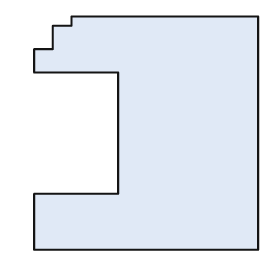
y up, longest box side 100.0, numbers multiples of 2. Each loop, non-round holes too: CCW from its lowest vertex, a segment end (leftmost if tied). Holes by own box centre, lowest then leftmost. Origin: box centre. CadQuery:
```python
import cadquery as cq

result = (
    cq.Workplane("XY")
    .moveTo(-48.0, -50.0)
    .lineTo(48.0, -50.0)
    .lineTo(48.0, 50.0)
    .lineTo(-32.0, 50.0)
    .lineTo(-32.0, 46.0)
    .lineTo(-40.0, 46.0)
    .lineTo(-40.0, 36.0)
    .lineTo(-48.0, 36.0)
    .lineTo(-48.0, 26.0)
    .lineTo(-12.0, 26.0)
    .lineTo(-12.0, -26.0)
    .lineTo(-48.0, -26.0)
    .close()
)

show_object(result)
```